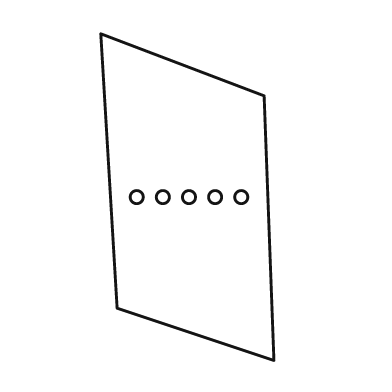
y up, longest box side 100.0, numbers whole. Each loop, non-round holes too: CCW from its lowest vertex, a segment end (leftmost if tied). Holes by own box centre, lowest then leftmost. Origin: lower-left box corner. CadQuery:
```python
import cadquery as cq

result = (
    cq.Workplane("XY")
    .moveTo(53.0, 0.0)
    .lineTo(50.0, 81.0)
    .lineTo(0.0, 100.0)
    .lineTo(5.0, 16.0)
    .close()
    .moveTo(11.0, 50.0)
    .circle(2.0)
    .moveTo(19.0, 50.0)
    .circle(2.0)
    .moveTo(27.0, 50.0)
    .circle(2.0)
    .moveTo(35.0, 50.0)
    .circle(2.0)
    .moveTo(43.0, 50.0)
    .circle(2.0)
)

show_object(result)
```